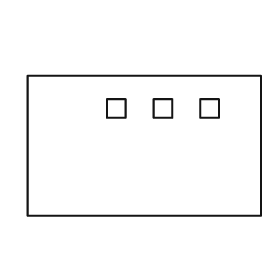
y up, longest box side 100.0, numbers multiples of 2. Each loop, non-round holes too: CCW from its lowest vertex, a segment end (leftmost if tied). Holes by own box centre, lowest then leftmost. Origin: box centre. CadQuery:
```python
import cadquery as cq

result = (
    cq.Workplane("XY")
    .moveTo(-50.0, -30.0)
    .lineTo(50.0, -30.0)
    .lineTo(50.0, 30.0)
    .lineTo(-50.0, 30.0)
    .close()
    .moveTo(-16.0, 12.0)
    .lineTo(-8.0, 12.0)
    .lineTo(-8.0, 20.0)
    .lineTo(-16.0, 20.0)
    .close()
    .moveTo(4.0, 12.0)
    .lineTo(12.0, 12.0)
    .lineTo(12.0, 20.0)
    .lineTo(4.0, 20.0)
    .close()
    .moveTo(24.0, 12.0)
    .lineTo(32.0, 12.0)
    .lineTo(32.0, 20.0)
    .lineTo(24.0, 20.0)
    .close()
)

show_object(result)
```